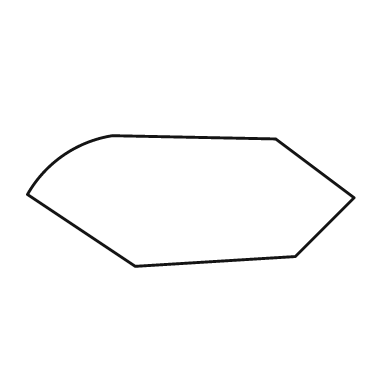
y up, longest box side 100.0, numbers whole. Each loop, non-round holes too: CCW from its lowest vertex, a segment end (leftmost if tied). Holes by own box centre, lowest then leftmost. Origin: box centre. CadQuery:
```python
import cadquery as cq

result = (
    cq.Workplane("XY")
    .moveTo(-17.0, -20.0)
    .lineTo(32.0, -17.0)
    .lineTo(50.0, 1.0)
    .lineTo(26.0, 19.0)
    .lineTo(-24.0, 20.0)
    .threePointArc((-39.0, 14.0), (-50.0, 2.0))
    .close()
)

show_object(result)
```